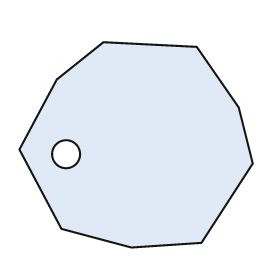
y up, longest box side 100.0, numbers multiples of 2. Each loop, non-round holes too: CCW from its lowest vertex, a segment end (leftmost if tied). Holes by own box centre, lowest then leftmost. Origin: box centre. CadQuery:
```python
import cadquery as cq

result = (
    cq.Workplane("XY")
    .moveTo(-2.0, -44.0)
    .lineTo(28.0, -42.0)
    .lineTo(50.0, -8.0)
    .lineTo(44.0, 16.0)
    .lineTo(26.0, 42.0)
    .lineTo(-14.0, 44.0)
    .lineTo(-34.0, 28.0)
    .lineTo(-50.0, -2.0)
    .lineTo(-32.0, -36.0)
    .close()
    .moveTo(-30.0, -4.0)
    .circle(6.0)
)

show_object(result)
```